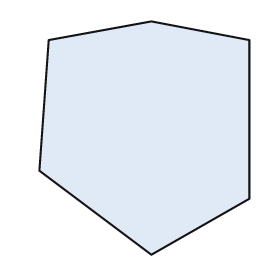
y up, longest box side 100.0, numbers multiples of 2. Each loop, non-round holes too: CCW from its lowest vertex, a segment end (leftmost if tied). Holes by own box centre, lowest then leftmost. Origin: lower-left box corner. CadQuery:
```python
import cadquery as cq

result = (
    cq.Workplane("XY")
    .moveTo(48.0, 0.0)
    .lineTo(90.0, 24.0)
    .lineTo(90.0, 92.0)
    .lineTo(48.0, 100.0)
    .lineTo(4.0, 92.0)
    .lineTo(0.0, 36.0)
    .close()
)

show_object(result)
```